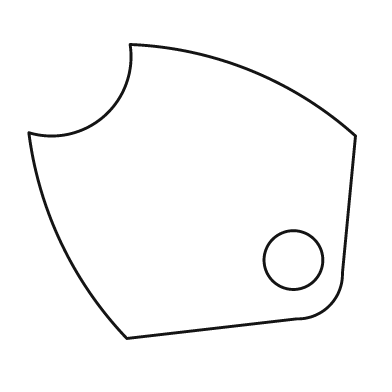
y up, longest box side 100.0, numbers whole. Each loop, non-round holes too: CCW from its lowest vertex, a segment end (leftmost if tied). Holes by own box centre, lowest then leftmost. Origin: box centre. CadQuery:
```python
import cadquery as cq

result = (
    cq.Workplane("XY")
    .moveTo(-20.0, -45.0)
    .lineTo(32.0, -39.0)
    .threePointArc((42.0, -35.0), (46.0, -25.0))
    .lineTo(50.0, 17.0)
    .threePointArc((18.0, 37.0), (-19.0, 45.0))
    .threePointArc((-27.0, 23.0), (-50.0, 18.0))
    .threePointArc((-40.0, -16.0), (-20.0, -45.0))
    .close()
    .moveTo(31.0, -21.0)
    .circle(9.0)
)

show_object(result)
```